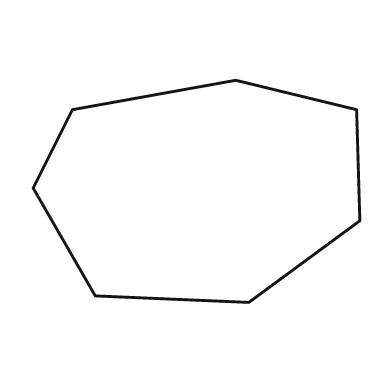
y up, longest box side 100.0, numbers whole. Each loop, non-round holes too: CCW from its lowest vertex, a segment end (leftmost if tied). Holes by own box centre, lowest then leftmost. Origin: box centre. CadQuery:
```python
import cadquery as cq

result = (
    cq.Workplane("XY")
    .moveTo(16.0, -34.0)
    .lineTo(50.0, -9.0)
    .lineTo(49.0, 25.0)
    .lineTo(12.0, 34.0)
    .lineTo(-38.0, 25.0)
    .lineTo(-50.0, 1.0)
    .lineTo(-31.0, -32.0)
    .close()
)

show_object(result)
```